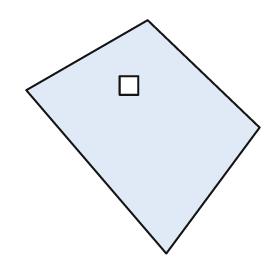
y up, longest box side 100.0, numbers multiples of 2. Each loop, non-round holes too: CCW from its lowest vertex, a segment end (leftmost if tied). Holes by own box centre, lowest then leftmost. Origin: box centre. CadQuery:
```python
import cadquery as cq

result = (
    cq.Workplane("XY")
    .moveTo(10.0, -50.0)
    .lineTo(50.0, 4.0)
    .lineTo(2.0, 50.0)
    .lineTo(-50.0, 20.0)
    .close()
    .moveTo(-10.0, 18.0)
    .lineTo(-2.0, 18.0)
    .lineTo(-2.0, 26.0)
    .lineTo(-10.0, 26.0)
    .close()
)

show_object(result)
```